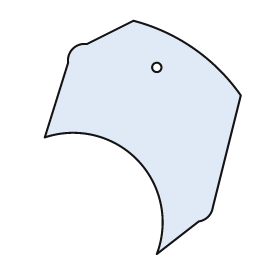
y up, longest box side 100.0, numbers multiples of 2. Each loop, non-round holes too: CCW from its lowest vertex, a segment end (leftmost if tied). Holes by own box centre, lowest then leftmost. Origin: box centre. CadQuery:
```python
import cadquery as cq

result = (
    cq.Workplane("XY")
    .moveTo(6.0, -50.0)
    .lineTo(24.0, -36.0)
    .threePointArc((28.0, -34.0), (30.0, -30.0))
    .lineTo(42.0, 18.0)
    .threePointArc((22.0, 38.0), (-4.0, 50.0))
    .lineTo(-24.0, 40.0)
    .threePointArc((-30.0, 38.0), (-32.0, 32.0))
    .lineTo(-42.0, 0.0)
    .threePointArc((-2.0, -10.0), (6.0, -50.0))
    .close()
    .moveTo(6.0, 30.0)
    .circle(2.0)
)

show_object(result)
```